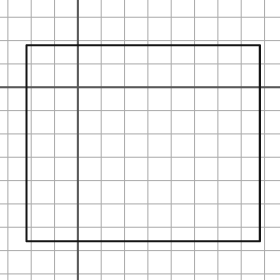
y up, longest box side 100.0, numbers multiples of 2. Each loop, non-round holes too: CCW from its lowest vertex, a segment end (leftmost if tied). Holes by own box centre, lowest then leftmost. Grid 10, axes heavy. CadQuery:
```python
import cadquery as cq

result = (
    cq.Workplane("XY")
    .moveTo(-22.0, -66.0)
    .lineTo(78.0, -66.0)
    .lineTo(78.0, 18.0)
    .lineTo(-22.0, 18.0)
    .close()
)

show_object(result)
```